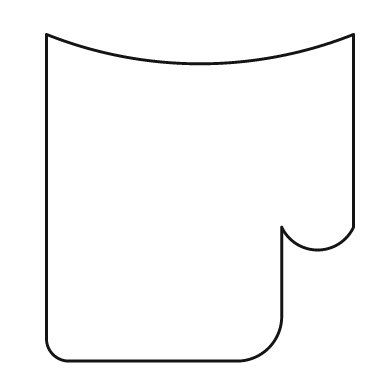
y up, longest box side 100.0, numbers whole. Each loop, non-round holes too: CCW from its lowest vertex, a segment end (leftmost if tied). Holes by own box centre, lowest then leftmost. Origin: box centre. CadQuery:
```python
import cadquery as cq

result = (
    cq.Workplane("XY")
    .moveTo(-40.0, -50.0)
    .lineTo(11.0, -50.0)
    .threePointArc((21.0, -46.0), (25.0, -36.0))
    .lineTo(25.0, -9.0)
    .threePointArc((36.0, -16.0), (47.0, -9.0))
    .lineTo(47.0, 50.0)
    .threePointArc((0.0, 41.0), (-47.0, 50.0))
    .lineTo(-47.0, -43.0)
    .threePointArc((-45.0, -48.0), (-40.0, -50.0))
    .close()
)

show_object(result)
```